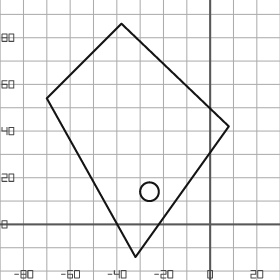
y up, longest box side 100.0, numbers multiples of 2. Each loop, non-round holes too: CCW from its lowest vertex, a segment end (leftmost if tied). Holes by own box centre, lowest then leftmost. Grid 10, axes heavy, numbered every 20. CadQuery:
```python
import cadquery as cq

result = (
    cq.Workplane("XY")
    .moveTo(-32.0, -14.0)
    .lineTo(8.0, 42.0)
    .lineTo(-38.0, 86.0)
    .lineTo(-70.0, 54.0)
    .close()
    .moveTo(-26.0, 14.0)
    .circle(4.0)
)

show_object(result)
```